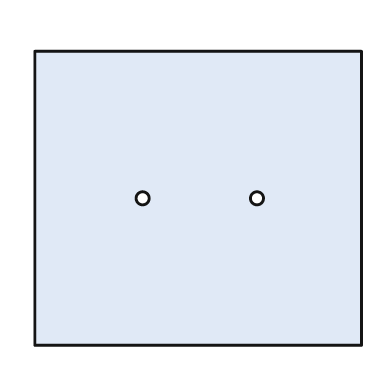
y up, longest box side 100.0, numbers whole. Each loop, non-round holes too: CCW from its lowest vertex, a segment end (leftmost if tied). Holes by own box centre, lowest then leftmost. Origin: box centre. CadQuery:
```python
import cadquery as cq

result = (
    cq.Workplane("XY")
    .moveTo(-50.0, -45.0)
    .lineTo(50.0, -45.0)
    .lineTo(50.0, 45.0)
    .lineTo(-50.0, 45.0)
    .close()
    .moveTo(-17.0, 0.0)
    .circle(2.0)
    .moveTo(18.0, 0.0)
    .circle(2.0)
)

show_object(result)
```